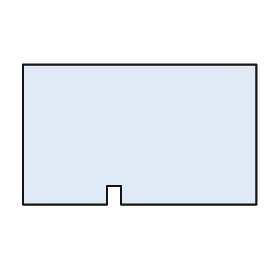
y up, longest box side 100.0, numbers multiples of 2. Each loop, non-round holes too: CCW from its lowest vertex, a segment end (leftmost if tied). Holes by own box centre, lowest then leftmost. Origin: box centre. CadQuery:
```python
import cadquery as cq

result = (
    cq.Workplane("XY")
    .moveTo(-50.0, -30.0)
    .lineTo(-14.0, -30.0)
    .lineTo(-14.0, -22.0)
    .lineTo(-8.0, -22.0)
    .lineTo(-8.0, -30.0)
    .lineTo(50.0, -30.0)
    .lineTo(50.0, 30.0)
    .lineTo(-50.0, 30.0)
    .close()
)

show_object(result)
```